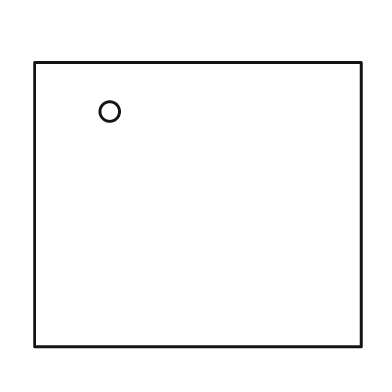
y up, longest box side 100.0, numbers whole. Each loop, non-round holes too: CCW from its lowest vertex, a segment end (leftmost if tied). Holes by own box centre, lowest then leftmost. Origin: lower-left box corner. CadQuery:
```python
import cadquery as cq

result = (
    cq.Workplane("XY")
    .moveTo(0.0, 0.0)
    .lineTo(100.0, 0.0)
    .lineTo(100.0, 87.0)
    .lineTo(0.0, 87.0)
    .close()
    .moveTo(23.0, 72.0)
    .circle(3.0)
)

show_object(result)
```